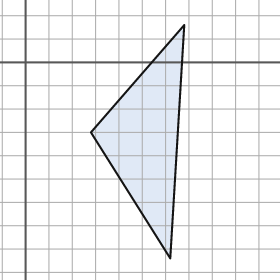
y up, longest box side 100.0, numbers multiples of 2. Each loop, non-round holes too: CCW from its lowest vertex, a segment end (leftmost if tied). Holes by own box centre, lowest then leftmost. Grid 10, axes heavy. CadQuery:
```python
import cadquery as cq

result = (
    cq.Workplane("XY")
    .moveTo(62.0, -84.0)
    .lineTo(68.0, 16.0)
    .lineTo(28.0, -30.0)
    .close()
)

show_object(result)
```